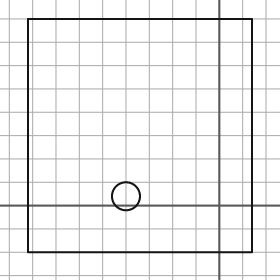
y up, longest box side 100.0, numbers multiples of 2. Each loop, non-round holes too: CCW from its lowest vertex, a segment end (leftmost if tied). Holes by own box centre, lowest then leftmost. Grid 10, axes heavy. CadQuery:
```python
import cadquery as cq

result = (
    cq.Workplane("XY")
    .moveTo(-82.0, -20.0)
    .lineTo(14.0, -20.0)
    .lineTo(14.0, 80.0)
    .lineTo(-82.0, 80.0)
    .close()
    .moveTo(-40.0, 4.0)
    .circle(6.0)
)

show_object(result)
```